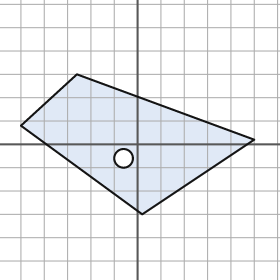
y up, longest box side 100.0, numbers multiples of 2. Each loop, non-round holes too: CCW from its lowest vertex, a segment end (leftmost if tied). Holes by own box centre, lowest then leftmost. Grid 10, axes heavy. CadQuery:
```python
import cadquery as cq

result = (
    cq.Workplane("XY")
    .moveTo(2.0, -30.0)
    .lineTo(50.0, 2.0)
    .lineTo(-26.0, 30.0)
    .lineTo(-50.0, 8.0)
    .close()
    .moveTo(-6.0, -6.0)
    .circle(4.0)
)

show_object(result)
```